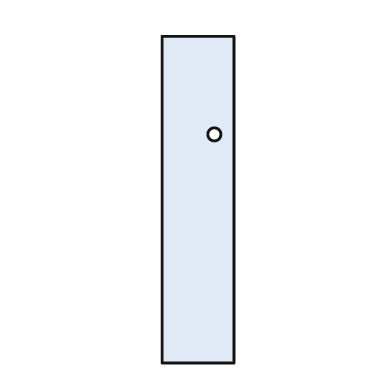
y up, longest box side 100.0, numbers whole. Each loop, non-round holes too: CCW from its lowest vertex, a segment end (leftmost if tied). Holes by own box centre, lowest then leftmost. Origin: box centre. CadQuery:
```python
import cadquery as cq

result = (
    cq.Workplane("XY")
    .moveTo(-11.0, -50.0)
    .lineTo(11.0, -50.0)
    .lineTo(11.0, 50.0)
    .lineTo(-11.0, 50.0)
    .close()
    .moveTo(5.0, 20.0)
    .circle(2.0)
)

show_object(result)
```